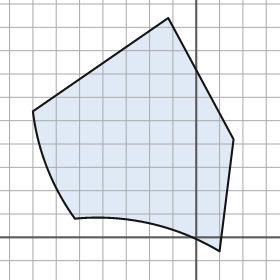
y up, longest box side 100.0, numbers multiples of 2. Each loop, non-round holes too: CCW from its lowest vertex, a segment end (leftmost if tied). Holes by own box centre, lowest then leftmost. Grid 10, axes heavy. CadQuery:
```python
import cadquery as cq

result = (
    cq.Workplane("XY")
    .moveTo(10.0, -6.0)
    .lineTo(16.0, 42.0)
    .lineTo(-12.0, 94.0)
    .lineTo(-70.0, 54.0)
    .threePointArc((-64.0, 30.0), (-52.0, 8.0))
    .threePointArc((-20.0, 6.0), (10.0, -6.0))
    .close()
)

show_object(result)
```